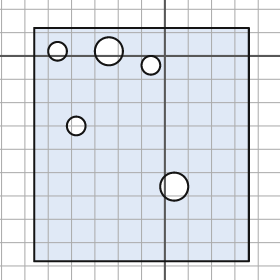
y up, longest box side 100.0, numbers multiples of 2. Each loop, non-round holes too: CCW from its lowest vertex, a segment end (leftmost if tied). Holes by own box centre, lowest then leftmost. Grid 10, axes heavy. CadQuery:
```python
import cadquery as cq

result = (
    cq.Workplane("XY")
    .moveTo(-56.0, -88.0)
    .lineTo(36.0, -88.0)
    .lineTo(36.0, 12.0)
    .lineTo(-56.0, 12.0)
    .close()
    .moveTo(4.0, -56.0)
    .circle(6.0)
    .moveTo(-38.0, -30.0)
    .circle(4.0)
    .moveTo(-6.0, -4.0)
    .circle(4.0)
    .moveTo(-46.0, 2.0)
    .circle(4.0)
    .moveTo(-24.0, 2.0)
    .circle(6.0)
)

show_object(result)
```